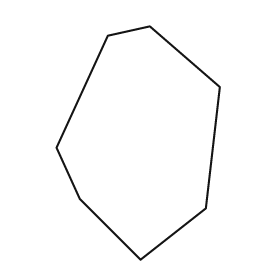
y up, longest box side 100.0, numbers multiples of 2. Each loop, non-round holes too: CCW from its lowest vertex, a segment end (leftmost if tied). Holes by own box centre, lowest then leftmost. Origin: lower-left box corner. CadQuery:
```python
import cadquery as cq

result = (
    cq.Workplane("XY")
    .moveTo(36.0, 0.0)
    .lineTo(64.0, 22.0)
    .lineTo(70.0, 74.0)
    .lineTo(40.0, 100.0)
    .lineTo(22.0, 96.0)
    .lineTo(0.0, 48.0)
    .lineTo(10.0, 26.0)
    .close()
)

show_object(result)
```